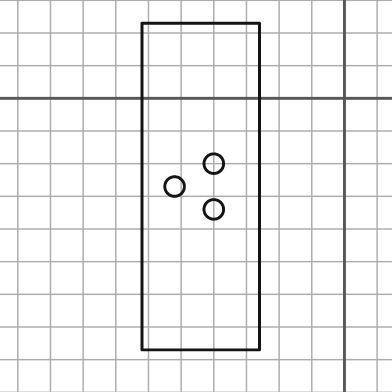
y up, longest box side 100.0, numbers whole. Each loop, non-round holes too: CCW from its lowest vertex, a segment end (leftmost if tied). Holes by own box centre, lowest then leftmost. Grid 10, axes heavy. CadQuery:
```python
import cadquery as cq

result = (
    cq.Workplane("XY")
    .moveTo(-62.0, -77.0)
    .lineTo(-26.0, -77.0)
    .lineTo(-26.0, 23.0)
    .lineTo(-62.0, 23.0)
    .close()
    .moveTo(-40.0, -34.0)
    .circle(3.0)
    .moveTo(-52.0, -27.0)
    .circle(3.0)
    .moveTo(-40.0, -20.0)
    .circle(3.0)
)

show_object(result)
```